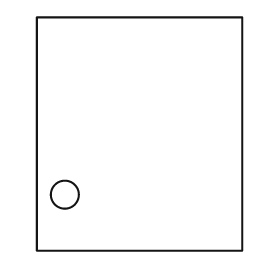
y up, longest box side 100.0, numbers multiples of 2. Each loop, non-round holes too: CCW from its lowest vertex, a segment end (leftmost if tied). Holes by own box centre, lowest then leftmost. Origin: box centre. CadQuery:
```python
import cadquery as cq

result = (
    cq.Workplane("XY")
    .moveTo(-44.0, -50.0)
    .lineTo(44.0, -50.0)
    .lineTo(44.0, 50.0)
    .lineTo(-44.0, 50.0)
    .close()
    .moveTo(-32.0, -26.0)
    .circle(6.0)
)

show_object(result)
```